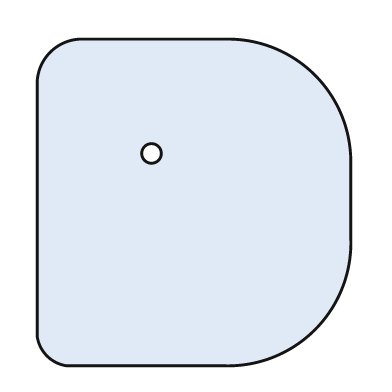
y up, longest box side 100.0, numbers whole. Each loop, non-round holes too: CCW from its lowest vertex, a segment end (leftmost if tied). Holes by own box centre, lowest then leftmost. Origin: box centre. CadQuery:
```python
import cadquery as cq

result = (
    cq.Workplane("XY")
    .moveTo(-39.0, -50.0)
    .lineTo(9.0, -50.0)
    .threePointArc((37.0, -39.0), (48.0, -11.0))
    .lineTo(48.0, 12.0)
    .threePointArc((37.0, 39.0), (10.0, 50.0))
    .lineTo(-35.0, 50.0)
    .threePointArc((-44.0, 46.0), (-48.0, 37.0))
    .lineTo(-48.0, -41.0)
    .threePointArc((-45.0, -47.0), (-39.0, -50.0))
    .close()
    .moveTo(-13.0, 15.0)
    .circle(3.0)
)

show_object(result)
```